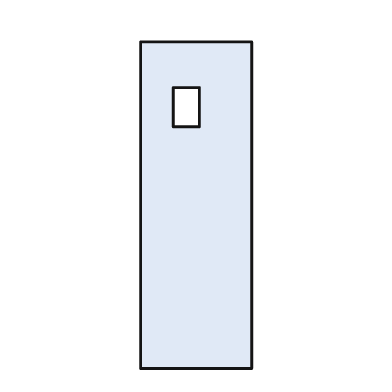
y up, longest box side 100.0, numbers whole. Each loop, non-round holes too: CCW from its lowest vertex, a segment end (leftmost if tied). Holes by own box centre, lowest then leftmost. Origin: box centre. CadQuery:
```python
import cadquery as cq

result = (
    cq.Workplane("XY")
    .moveTo(-17.0, -50.0)
    .lineTo(17.0, -50.0)
    .lineTo(17.0, 50.0)
    .lineTo(-17.0, 50.0)
    .close()
    .moveTo(-7.0, 24.0)
    .lineTo(1.0, 24.0)
    .lineTo(1.0, 36.0)
    .lineTo(-7.0, 36.0)
    .close()
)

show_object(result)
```